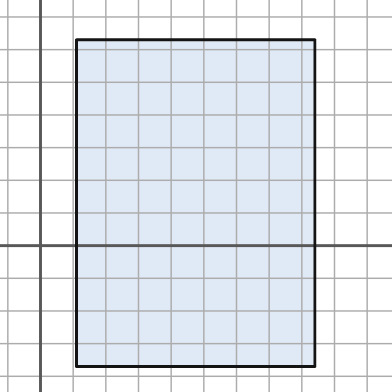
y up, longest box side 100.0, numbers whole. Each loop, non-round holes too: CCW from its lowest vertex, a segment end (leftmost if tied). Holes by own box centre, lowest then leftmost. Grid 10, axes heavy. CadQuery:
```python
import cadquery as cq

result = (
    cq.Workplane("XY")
    .moveTo(11.0, -37.0)
    .lineTo(84.0, -37.0)
    .lineTo(84.0, 63.0)
    .lineTo(11.0, 63.0)
    .close()
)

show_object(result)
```